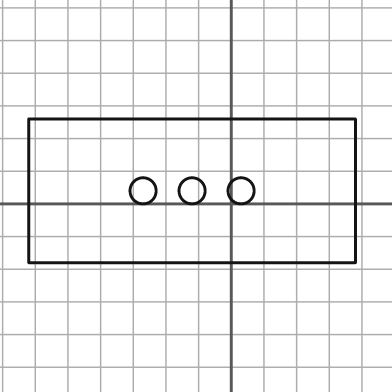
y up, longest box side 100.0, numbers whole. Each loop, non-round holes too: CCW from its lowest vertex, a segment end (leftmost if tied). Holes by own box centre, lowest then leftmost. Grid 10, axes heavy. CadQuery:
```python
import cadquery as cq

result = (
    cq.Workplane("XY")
    .moveTo(-62.0, -18.0)
    .lineTo(38.0, -18.0)
    .lineTo(38.0, 26.0)
    .lineTo(-62.0, 26.0)
    .close()
    .moveTo(-27.0, 4.0)
    .circle(4.0)
    .moveTo(-12.0, 4.0)
    .circle(4.0)
    .moveTo(3.0, 4.0)
    .circle(4.0)
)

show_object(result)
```